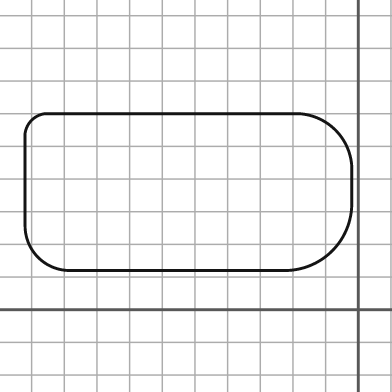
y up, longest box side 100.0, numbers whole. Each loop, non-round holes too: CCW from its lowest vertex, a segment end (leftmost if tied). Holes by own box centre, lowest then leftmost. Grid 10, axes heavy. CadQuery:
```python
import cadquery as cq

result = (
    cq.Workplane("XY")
    .moveTo(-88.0, 12.0)
    .lineTo(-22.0, 12.0)
    .threePointArc((-8.0, 18.0), (-2.0, 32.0))
    .lineTo(-2.0, 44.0)
    .threePointArc((-7.0, 55.0), (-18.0, 60.0))
    .lineTo(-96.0, 60.0)
    .threePointArc((-100.0, 58.0), (-102.0, 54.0))
    .lineTo(-102.0, 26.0)
    .threePointArc((-98.0, 16.0), (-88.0, 12.0))
    .close()
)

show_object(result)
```